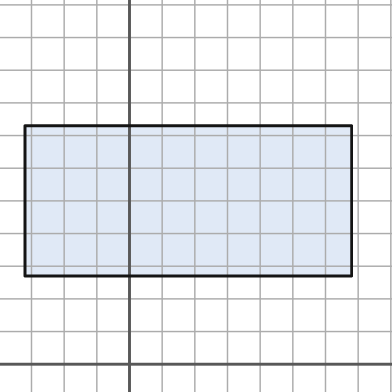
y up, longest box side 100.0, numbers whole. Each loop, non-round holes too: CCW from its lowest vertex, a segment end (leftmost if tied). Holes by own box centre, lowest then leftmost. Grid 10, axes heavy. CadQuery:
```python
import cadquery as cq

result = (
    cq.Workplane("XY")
    .moveTo(-32.0, 27.0)
    .lineTo(68.0, 27.0)
    .lineTo(68.0, 73.0)
    .lineTo(-32.0, 73.0)
    .close()
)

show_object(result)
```